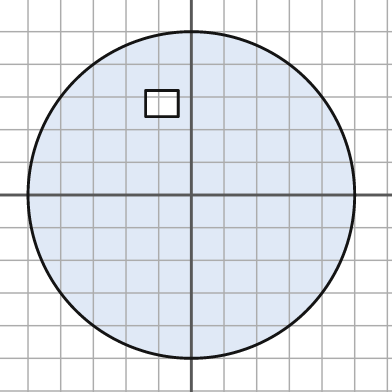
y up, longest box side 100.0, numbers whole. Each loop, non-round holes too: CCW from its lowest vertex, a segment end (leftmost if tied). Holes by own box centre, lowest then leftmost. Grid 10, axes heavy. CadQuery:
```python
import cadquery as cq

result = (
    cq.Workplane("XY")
    .moveTo(0.0, 0.0)
    .circle(50.0)
    .moveTo(-14.0, 24.0)
    .lineTo(-4.0, 24.0)
    .lineTo(-4.0, 32.0)
    .lineTo(-14.0, 32.0)
    .close()
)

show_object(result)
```